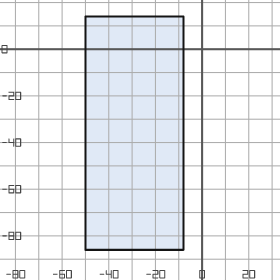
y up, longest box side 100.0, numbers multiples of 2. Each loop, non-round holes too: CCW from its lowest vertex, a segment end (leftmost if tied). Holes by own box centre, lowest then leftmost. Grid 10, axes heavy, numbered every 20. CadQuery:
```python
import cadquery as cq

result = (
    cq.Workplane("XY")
    .moveTo(-50.0, -86.0)
    .lineTo(-8.0, -86.0)
    .lineTo(-8.0, 14.0)
    .lineTo(-50.0, 14.0)
    .close()
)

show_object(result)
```